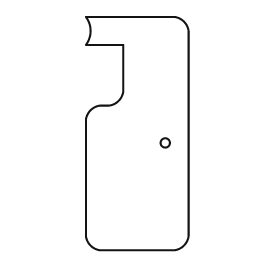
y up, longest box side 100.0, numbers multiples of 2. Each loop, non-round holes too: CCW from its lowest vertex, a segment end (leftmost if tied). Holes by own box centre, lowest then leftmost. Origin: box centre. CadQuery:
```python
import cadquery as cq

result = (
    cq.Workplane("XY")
    .moveTo(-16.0, -50.0)
    .lineTo(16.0, -50.0)
    .threePointArc((20.0, -48.0), (22.0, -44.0))
    .lineTo(22.0, 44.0)
    .threePointArc((20.0, 48.0), (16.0, 50.0))
    .lineTo(-22.0, 50.0)
    .threePointArc((-20.0, 44.0), (-22.0, 38.0))
    .lineTo(-6.0, 38.0)
    .lineTo(-6.0, 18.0)
    .threePointArc((-8.0, 14.0), (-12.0, 12.0))
    .lineTo(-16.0, 12.0)
    .threePointArc((-20.0, 10.0), (-22.0, 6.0))
    .lineTo(-22.0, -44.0)
    .threePointArc((-20.0, -48.0), (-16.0, -50.0))
    .close()
    .moveTo(12.0, -4.0)
    .circle(2.0)
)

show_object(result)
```